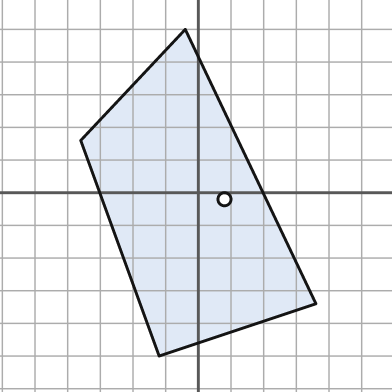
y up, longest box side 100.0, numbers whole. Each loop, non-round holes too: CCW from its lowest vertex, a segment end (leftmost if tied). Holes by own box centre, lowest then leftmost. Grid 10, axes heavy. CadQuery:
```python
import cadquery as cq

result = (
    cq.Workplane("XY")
    .moveTo(-12.0, -50.0)
    .lineTo(36.0, -34.0)
    .lineTo(-4.0, 50.0)
    .lineTo(-36.0, 16.0)
    .close()
    .moveTo(8.0, -2.0)
    .circle(2.0)
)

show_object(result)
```